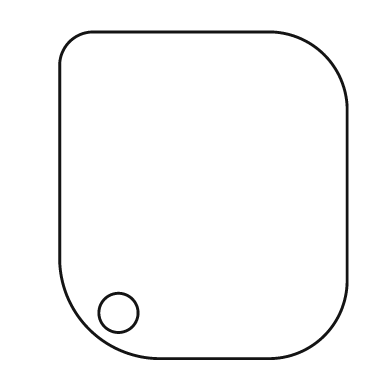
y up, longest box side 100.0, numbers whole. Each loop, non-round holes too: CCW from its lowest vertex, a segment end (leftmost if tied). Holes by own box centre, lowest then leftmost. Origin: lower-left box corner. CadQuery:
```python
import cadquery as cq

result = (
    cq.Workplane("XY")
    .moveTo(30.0, 0.0)
    .lineTo(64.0, 0.0)
    .threePointArc((81.0, 7.0), (88.0, 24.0))
    .lineTo(88.0, 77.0)
    .threePointArc((81.0, 93.0), (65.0, 100.0))
    .lineTo(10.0, 100.0)
    .threePointArc((3.0, 97.0), (0.0, 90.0))
    .lineTo(0.0, 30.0)
    .threePointArc((9.0, 9.0), (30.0, 0.0))
    .close()
    .moveTo(18.0, 14.0)
    .circle(6.0)
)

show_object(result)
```